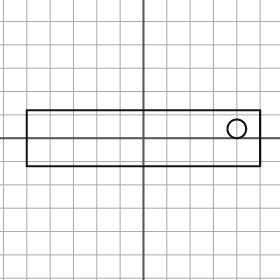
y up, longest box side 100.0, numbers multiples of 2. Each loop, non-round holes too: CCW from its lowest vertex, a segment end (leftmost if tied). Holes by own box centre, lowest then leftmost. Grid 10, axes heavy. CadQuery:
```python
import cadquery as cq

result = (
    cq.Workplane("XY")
    .moveTo(-50.0, -12.0)
    .lineTo(50.0, -12.0)
    .lineTo(50.0, 12.0)
    .lineTo(-50.0, 12.0)
    .close()
    .moveTo(40.0, 4.0)
    .circle(4.0)
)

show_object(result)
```